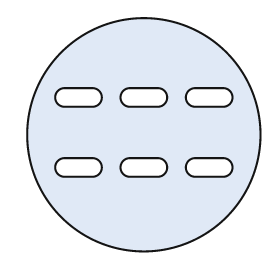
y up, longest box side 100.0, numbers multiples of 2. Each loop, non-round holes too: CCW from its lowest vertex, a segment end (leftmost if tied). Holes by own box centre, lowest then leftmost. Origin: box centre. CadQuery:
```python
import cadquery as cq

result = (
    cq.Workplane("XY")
    .moveTo(0.0, 0.0)
    .circle(50.0)
    .moveTo(-34.0, -18.0)
    .lineTo(-22.0, -18.0)
    .threePointArc((-18.0, -14.0), (-22.0, -10.0))
    .lineTo(-34.0, -10.0)
    .threePointArc((-38.0, -14.0), (-34.0, -18.0))
    .close()
    .moveTo(-6.0, -18.0)
    .lineTo(6.0, -18.0)
    .threePointArc((10.0, -14.0), (6.0, -10.0))
    .lineTo(-6.0, -10.0)
    .threePointArc((-10.0, -14.0), (-6.0, -18.0))
    .close()
    .moveTo(22.0, -18.0)
    .lineTo(34.0, -18.0)
    .threePointArc((38.0, -14.0), (34.0, -10.0))
    .lineTo(22.0, -10.0)
    .threePointArc((18.0, -14.0), (22.0, -18.0))
    .close()
    .moveTo(-34.0, 12.0)
    .lineTo(-22.0, 12.0)
    .threePointArc((-18.0, 16.0), (-22.0, 20.0))
    .lineTo(-34.0, 20.0)
    .threePointArc((-38.0, 16.0), (-34.0, 12.0))
    .close()
    .moveTo(-6.0, 12.0)
    .lineTo(6.0, 12.0)
    .threePointArc((10.0, 16.0), (6.0, 20.0))
    .lineTo(-6.0, 20.0)
    .threePointArc((-10.0, 16.0), (-6.0, 12.0))
    .close()
    .moveTo(22.0, 12.0)
    .lineTo(34.0, 12.0)
    .threePointArc((38.0, 16.0), (34.0, 20.0))
    .lineTo(22.0, 20.0)
    .threePointArc((18.0, 16.0), (22.0, 12.0))
    .close()
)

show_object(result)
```